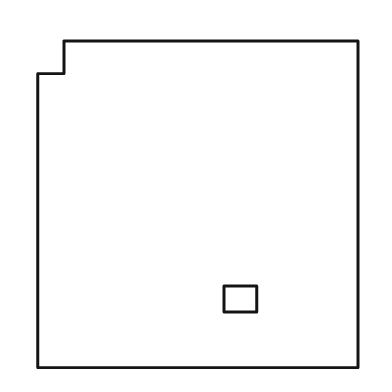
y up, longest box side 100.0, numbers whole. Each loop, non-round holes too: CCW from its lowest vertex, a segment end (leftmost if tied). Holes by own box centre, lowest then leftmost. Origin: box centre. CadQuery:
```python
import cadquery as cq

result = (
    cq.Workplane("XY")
    .moveTo(-49.0, -50.0)
    .lineTo(49.0, -50.0)
    .lineTo(49.0, 50.0)
    .lineTo(-41.0, 50.0)
    .lineTo(-41.0, 40.0)
    .lineTo(-49.0, 40.0)
    .close()
    .moveTo(8.0, -33.0)
    .lineTo(18.0, -33.0)
    .lineTo(18.0, -25.0)
    .lineTo(8.0, -25.0)
    .close()
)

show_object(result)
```